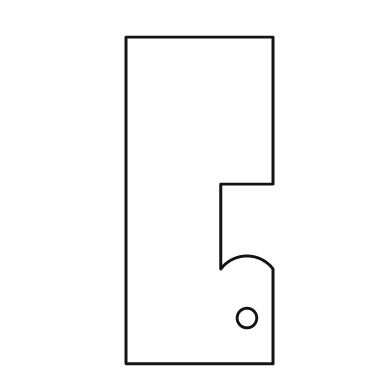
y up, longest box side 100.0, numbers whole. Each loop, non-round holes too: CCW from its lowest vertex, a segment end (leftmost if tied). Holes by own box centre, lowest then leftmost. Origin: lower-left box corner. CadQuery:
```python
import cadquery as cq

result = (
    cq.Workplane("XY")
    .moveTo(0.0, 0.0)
    .lineTo(45.0, 0.0)
    .lineTo(45.0, 29.0)
    .threePointArc((37.0, 33.0), (29.0, 29.0))
    .lineTo(29.0, 55.0)
    .lineTo(45.0, 55.0)
    .lineTo(45.0, 100.0)
    .lineTo(0.0, 100.0)
    .close()
    .moveTo(37.0, 14.0)
    .circle(3.0)
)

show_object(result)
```